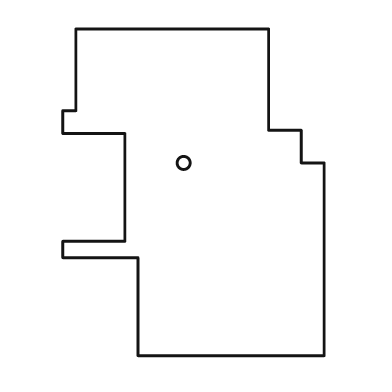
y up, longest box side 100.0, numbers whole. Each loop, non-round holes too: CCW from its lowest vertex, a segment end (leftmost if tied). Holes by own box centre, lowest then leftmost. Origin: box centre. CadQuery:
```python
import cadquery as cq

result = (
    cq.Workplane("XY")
    .moveTo(-17.0, -50.0)
    .lineTo(40.0, -50.0)
    .lineTo(40.0, 9.0)
    .lineTo(33.0, 9.0)
    .lineTo(33.0, 19.0)
    .lineTo(23.0, 19.0)
    .lineTo(23.0, 50.0)
    .lineTo(-36.0, 50.0)
    .lineTo(-36.0, 25.0)
    .lineTo(-40.0, 25.0)
    .lineTo(-40.0, 18.0)
    .lineTo(-21.0, 18.0)
    .lineTo(-21.0, -15.0)
    .lineTo(-40.0, -15.0)
    .lineTo(-40.0, -20.0)
    .lineTo(-17.0, -20.0)
    .close()
    .moveTo(-3.0, 9.0)
    .circle(2.0)
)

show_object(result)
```